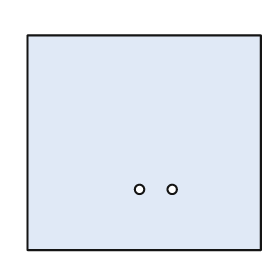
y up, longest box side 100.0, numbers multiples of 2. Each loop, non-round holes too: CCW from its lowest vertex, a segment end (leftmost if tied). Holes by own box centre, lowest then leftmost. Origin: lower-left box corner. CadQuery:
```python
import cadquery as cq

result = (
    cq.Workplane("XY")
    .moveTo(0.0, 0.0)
    .lineTo(100.0, 0.0)
    .lineTo(100.0, 92.0)
    .lineTo(0.0, 92.0)
    .close()
    .moveTo(48.0, 26.0)
    .circle(2.0)
    .moveTo(62.0, 26.0)
    .circle(2.0)
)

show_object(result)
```